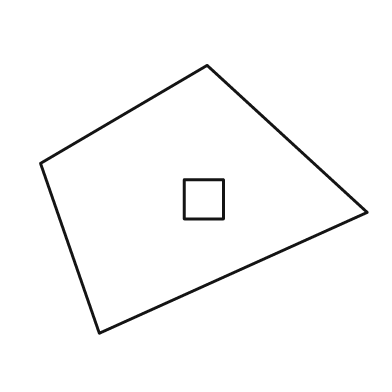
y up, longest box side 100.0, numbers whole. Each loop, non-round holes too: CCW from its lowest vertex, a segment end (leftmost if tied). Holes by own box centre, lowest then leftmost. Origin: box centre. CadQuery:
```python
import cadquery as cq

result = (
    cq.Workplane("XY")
    .moveTo(-32.0, -41.0)
    .lineTo(50.0, -4.0)
    .lineTo(1.0, 41.0)
    .lineTo(-50.0, 11.0)
    .close()
    .moveTo(-6.0, -6.0)
    .lineTo(6.0, -6.0)
    .lineTo(6.0, 6.0)
    .lineTo(-6.0, 6.0)
    .close()
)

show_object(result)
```